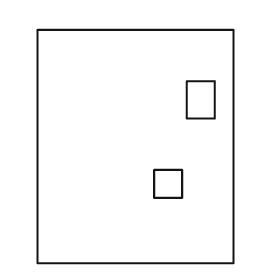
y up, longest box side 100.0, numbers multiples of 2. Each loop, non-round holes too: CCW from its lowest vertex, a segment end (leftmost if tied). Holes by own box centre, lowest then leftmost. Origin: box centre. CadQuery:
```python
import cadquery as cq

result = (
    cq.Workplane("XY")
    .moveTo(-42.0, -50.0)
    .lineTo(42.0, -50.0)
    .lineTo(42.0, 50.0)
    .lineTo(-42.0, 50.0)
    .close()
    .moveTo(8.0, -22.0)
    .lineTo(20.0, -22.0)
    .lineTo(20.0, -10.0)
    .lineTo(8.0, -10.0)
    .close()
    .moveTo(22.0, 12.0)
    .lineTo(34.0, 12.0)
    .lineTo(34.0, 28.0)
    .lineTo(22.0, 28.0)
    .close()
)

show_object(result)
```